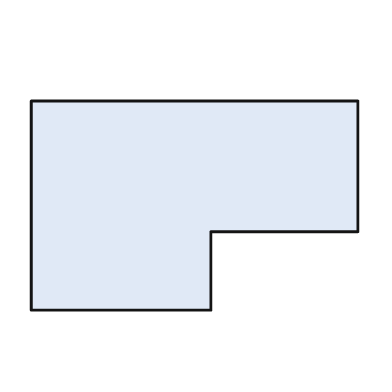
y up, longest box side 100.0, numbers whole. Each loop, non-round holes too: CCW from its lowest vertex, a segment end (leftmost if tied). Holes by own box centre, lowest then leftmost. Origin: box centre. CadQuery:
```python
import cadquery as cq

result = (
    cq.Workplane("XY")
    .moveTo(-50.0, -32.0)
    .lineTo(5.0, -32.0)
    .lineTo(5.0, -8.0)
    .lineTo(50.0, -8.0)
    .lineTo(50.0, 32.0)
    .lineTo(-50.0, 32.0)
    .close()
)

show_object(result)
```